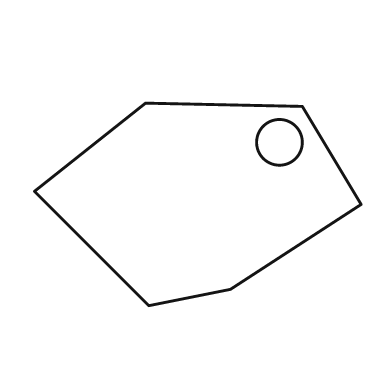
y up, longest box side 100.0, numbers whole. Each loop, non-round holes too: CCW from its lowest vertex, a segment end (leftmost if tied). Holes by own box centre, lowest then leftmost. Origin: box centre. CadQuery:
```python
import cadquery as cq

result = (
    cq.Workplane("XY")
    .moveTo(-15.0, -31.0)
    .lineTo(10.0, -26.0)
    .lineTo(50.0, 0.0)
    .lineTo(32.0, 30.0)
    .lineTo(-16.0, 31.0)
    .lineTo(-50.0, 4.0)
    .close()
    .moveTo(25.0, 19.0)
    .circle(7.0)
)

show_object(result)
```